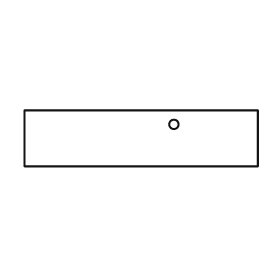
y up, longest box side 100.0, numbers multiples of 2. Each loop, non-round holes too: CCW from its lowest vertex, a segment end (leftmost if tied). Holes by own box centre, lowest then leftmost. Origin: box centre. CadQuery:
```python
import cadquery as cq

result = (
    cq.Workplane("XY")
    .moveTo(-50.0, -12.0)
    .lineTo(50.0, -12.0)
    .lineTo(50.0, 12.0)
    .lineTo(-50.0, 12.0)
    .close()
    .moveTo(14.0, 6.0)
    .circle(2.0)
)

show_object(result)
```